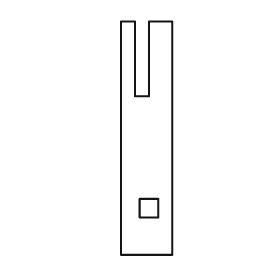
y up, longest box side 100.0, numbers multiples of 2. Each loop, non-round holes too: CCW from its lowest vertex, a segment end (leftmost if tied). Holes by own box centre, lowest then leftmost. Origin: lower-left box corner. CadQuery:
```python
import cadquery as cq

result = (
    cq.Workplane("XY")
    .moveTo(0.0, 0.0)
    .lineTo(22.0, 0.0)
    .lineTo(22.0, 100.0)
    .lineTo(12.0, 100.0)
    .lineTo(12.0, 68.0)
    .lineTo(6.0, 68.0)
    .lineTo(6.0, 100.0)
    .lineTo(0.0, 100.0)
    .close()
    .moveTo(8.0, 16.0)
    .lineTo(16.0, 16.0)
    .lineTo(16.0, 24.0)
    .lineTo(8.0, 24.0)
    .close()
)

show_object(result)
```